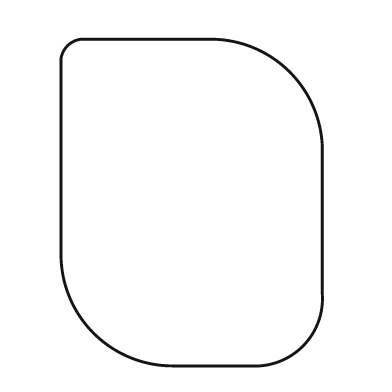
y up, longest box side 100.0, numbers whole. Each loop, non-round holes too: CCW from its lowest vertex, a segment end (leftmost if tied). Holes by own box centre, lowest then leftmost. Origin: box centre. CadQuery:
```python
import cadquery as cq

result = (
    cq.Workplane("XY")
    .moveTo(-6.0, -50.0)
    .lineTo(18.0, -50.0)
    .threePointArc((34.0, -44.0), (40.0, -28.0))
    .lineTo(40.0, 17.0)
    .threePointArc((30.0, 40.0), (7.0, 50.0))
    .lineTo(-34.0, 50.0)
    .threePointArc((-38.0, 48.0), (-40.0, 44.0))
    .lineTo(-40.0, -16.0)
    .threePointArc((-30.0, -40.0), (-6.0, -50.0))
    .close()
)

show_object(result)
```